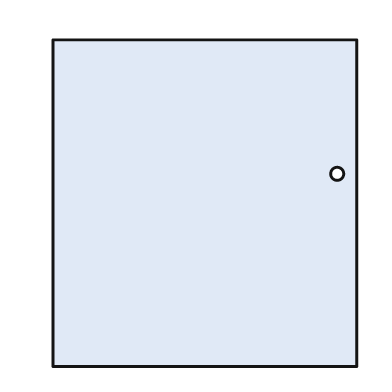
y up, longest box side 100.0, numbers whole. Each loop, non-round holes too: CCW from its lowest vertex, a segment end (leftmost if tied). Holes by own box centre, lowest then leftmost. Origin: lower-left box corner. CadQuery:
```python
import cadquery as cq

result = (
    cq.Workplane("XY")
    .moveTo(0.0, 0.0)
    .lineTo(93.0, 0.0)
    .lineTo(93.0, 100.0)
    .lineTo(0.0, 100.0)
    .close()
    .moveTo(87.0, 59.0)
    .circle(2.0)
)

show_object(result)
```